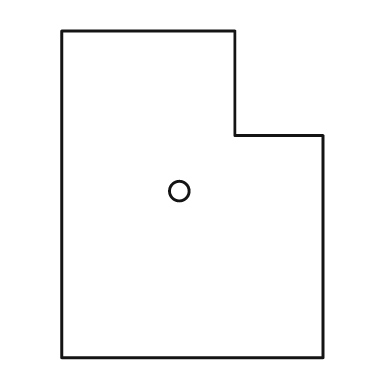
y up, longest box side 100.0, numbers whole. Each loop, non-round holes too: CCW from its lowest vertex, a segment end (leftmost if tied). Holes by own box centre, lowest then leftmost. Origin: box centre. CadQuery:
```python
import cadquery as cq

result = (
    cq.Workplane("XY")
    .moveTo(-40.0, -50.0)
    .lineTo(40.0, -50.0)
    .lineTo(40.0, 18.0)
    .lineTo(13.0, 18.0)
    .lineTo(13.0, 50.0)
    .lineTo(-40.0, 50.0)
    .close()
    .moveTo(-4.0, 1.0)
    .circle(3.0)
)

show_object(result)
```